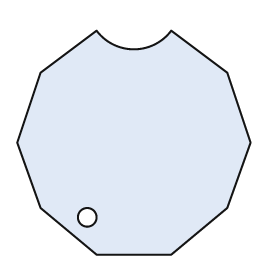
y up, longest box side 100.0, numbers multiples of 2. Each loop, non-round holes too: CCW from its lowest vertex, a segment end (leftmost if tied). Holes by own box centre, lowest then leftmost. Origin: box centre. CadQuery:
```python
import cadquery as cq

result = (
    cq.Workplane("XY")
    .moveTo(-16.0, -48.0)
    .lineTo(16.0, -48.0)
    .lineTo(40.0, -28.0)
    .lineTo(50.0, 0.0)
    .lineTo(40.0, 30.0)
    .lineTo(16.0, 48.0)
    .threePointArc((0.0, 40.0), (-16.0, 48.0))
    .lineTo(-40.0, 30.0)
    .lineTo(-50.0, 0.0)
    .lineTo(-40.0, -28.0)
    .close()
    .moveTo(-20.0, -32.0)
    .circle(4.0)
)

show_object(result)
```